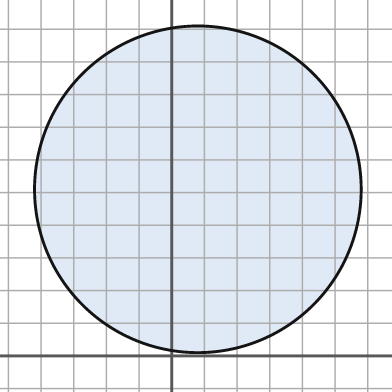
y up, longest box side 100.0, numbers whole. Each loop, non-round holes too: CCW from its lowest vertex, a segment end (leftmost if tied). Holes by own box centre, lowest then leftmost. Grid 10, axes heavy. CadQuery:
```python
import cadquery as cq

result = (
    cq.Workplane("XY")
    .moveTo(8.0, 51.0)
    .circle(50.0)
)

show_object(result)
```